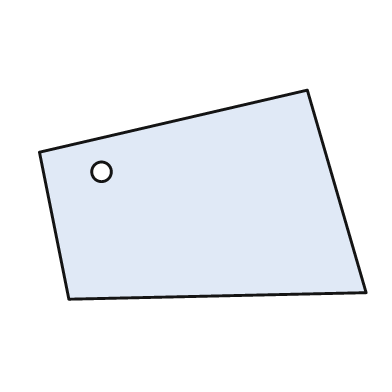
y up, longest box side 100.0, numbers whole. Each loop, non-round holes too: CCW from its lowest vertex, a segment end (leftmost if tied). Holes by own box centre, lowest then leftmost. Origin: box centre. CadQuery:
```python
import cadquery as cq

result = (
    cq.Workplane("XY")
    .moveTo(-41.0, -32.0)
    .lineTo(50.0, -30.0)
    .lineTo(32.0, 32.0)
    .lineTo(-50.0, 13.0)
    .close()
    .moveTo(-31.0, 7.0)
    .circle(3.0)
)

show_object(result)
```